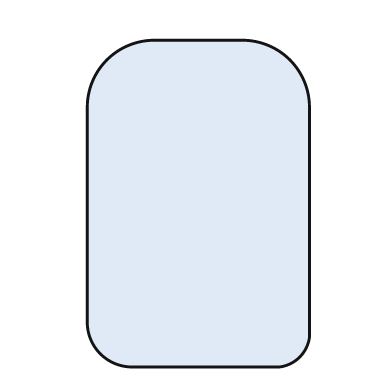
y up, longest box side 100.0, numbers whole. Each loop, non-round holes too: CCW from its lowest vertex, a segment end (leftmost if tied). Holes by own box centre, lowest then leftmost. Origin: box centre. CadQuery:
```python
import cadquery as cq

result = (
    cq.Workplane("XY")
    .moveTo(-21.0, -50.0)
    .lineTo(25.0, -50.0)
    .threePointArc((31.0, -47.0), (34.0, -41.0))
    .lineTo(34.0, 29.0)
    .threePointArc((28.0, 44.0), (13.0, 50.0))
    .lineTo(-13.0, 50.0)
    .threePointArc((-28.0, 44.0), (-34.0, 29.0))
    .lineTo(-34.0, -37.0)
    .threePointArc((-30.0, -46.0), (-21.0, -50.0))
    .close()
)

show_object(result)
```